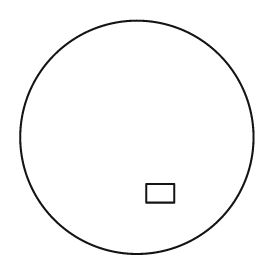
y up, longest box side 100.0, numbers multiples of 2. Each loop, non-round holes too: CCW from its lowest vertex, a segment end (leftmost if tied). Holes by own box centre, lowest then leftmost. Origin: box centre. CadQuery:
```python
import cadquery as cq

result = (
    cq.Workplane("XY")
    .moveTo(0.0, 0.0)
    .circle(50.0)
    .moveTo(4.0, -28.0)
    .lineTo(16.0, -28.0)
    .lineTo(16.0, -20.0)
    .lineTo(4.0, -20.0)
    .close()
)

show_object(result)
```